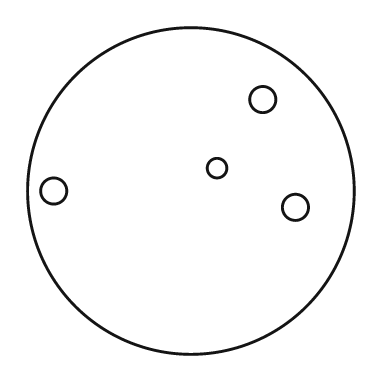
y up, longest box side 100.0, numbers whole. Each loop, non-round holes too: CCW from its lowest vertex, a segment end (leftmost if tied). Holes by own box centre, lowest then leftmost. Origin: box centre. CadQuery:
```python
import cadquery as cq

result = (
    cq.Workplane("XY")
    .moveTo(0.0, 0.0)
    .circle(50.0)
    .moveTo(32.0, -5.0)
    .circle(4.0)
    .moveTo(-42.0, 0.0)
    .circle(4.0)
    .moveTo(8.0, 7.0)
    .circle(3.0)
    .moveTo(22.0, 28.0)
    .circle(4.0)
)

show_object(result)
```